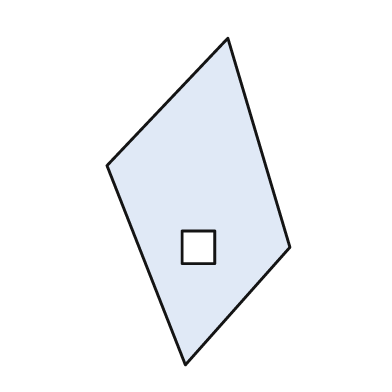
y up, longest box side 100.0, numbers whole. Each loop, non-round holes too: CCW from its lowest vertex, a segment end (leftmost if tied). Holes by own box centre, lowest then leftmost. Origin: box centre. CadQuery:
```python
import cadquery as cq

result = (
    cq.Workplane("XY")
    .moveTo(-4.0, -50.0)
    .lineTo(28.0, -14.0)
    .lineTo(9.0, 50.0)
    .lineTo(-28.0, 11.0)
    .close()
    .moveTo(-5.0, -19.0)
    .lineTo(5.0, -19.0)
    .lineTo(5.0, -9.0)
    .lineTo(-5.0, -9.0)
    .close()
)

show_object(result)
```